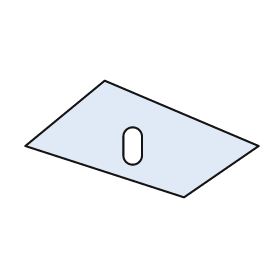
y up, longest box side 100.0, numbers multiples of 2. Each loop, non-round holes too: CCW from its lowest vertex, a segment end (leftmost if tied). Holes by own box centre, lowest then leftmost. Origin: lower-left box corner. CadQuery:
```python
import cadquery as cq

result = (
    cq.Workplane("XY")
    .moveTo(68.0, 0.0)
    .lineTo(100.0, 22.0)
    .lineTo(34.0, 50.0)
    .lineTo(0.0, 22.0)
    .close()
    .moveTo(42.0, 18.0)
    .threePointArc((46.0, 14.0), (50.0, 18.0))
    .lineTo(50.0, 26.0)
    .threePointArc((46.0, 30.0), (42.0, 26.0))
    .close()
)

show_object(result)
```